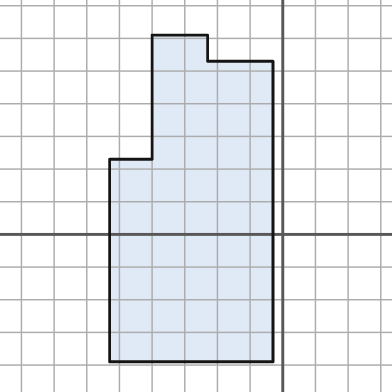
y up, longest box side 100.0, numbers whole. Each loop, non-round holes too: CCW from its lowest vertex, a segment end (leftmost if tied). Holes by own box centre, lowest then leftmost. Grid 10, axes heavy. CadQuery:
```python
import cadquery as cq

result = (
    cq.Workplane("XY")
    .moveTo(-53.0, -39.0)
    .lineTo(-3.0, -39.0)
    .lineTo(-3.0, 53.0)
    .lineTo(-23.0, 53.0)
    .lineTo(-23.0, 61.0)
    .lineTo(-40.0, 61.0)
    .lineTo(-40.0, 23.0)
    .lineTo(-53.0, 23.0)
    .close()
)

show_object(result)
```